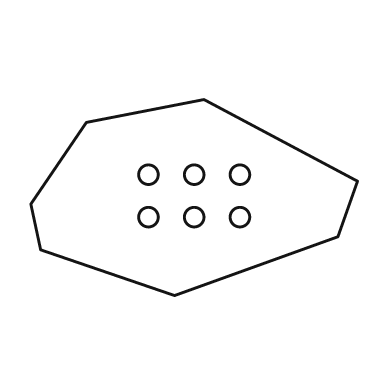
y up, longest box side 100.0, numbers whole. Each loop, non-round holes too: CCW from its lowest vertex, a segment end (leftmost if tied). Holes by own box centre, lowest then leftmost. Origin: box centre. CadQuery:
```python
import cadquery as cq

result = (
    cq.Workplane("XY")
    .moveTo(-6.0, -30.0)
    .lineTo(44.0, -12.0)
    .lineTo(50.0, 5.0)
    .lineTo(3.0, 30.0)
    .lineTo(-33.0, 23.0)
    .lineTo(-50.0, -2.0)
    .lineTo(-47.0, -16.0)
    .close()
    .moveTo(-14.0, -6.0)
    .circle(3.0)
    .moveTo(0.0, -6.0)
    .circle(3.0)
    .moveTo(14.0, -6.0)
    .circle(3.0)
    .moveTo(-14.0, 7.0)
    .circle(3.0)
    .moveTo(0.0, 7.0)
    .circle(3.0)
    .moveTo(14.0, 7.0)
    .circle(3.0)
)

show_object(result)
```